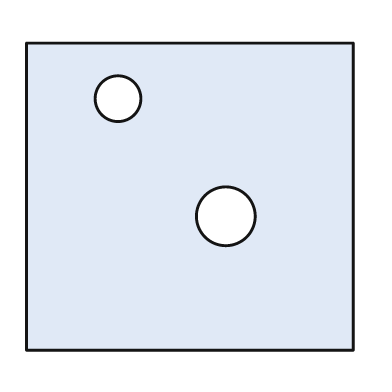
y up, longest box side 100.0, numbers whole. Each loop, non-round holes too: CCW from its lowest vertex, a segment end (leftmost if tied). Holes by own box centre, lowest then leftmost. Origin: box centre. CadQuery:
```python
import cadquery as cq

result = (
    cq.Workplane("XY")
    .moveTo(-50.0, -47.0)
    .lineTo(50.0, -47.0)
    .lineTo(50.0, 47.0)
    .lineTo(-50.0, 47.0)
    .close()
    .moveTo(11.0, -6.0)
    .circle(9.0)
    .moveTo(-22.0, 30.0)
    .circle(7.0)
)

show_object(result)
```